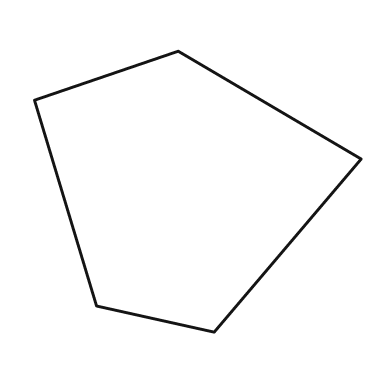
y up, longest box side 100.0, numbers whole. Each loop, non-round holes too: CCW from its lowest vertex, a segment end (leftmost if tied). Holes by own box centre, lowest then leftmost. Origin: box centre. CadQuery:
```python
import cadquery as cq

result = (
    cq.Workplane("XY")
    .moveTo(5.0, -43.0)
    .lineTo(50.0, 10.0)
    .lineTo(-6.0, 43.0)
    .lineTo(-50.0, 28.0)
    .lineTo(-31.0, -35.0)
    .close()
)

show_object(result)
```